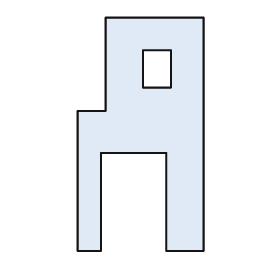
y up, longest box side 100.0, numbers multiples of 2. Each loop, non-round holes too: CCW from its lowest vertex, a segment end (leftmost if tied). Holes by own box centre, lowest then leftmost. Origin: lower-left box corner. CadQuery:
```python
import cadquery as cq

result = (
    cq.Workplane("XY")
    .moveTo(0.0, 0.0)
    .lineTo(10.0, 0.0)
    .lineTo(10.0, 42.0)
    .lineTo(38.0, 42.0)
    .lineTo(38.0, 0.0)
    .lineTo(54.0, 0.0)
    .lineTo(54.0, 100.0)
    .lineTo(12.0, 100.0)
    .lineTo(12.0, 60.0)
    .lineTo(0.0, 60.0)
    .close()
    .moveTo(28.0, 70.0)
    .lineTo(40.0, 70.0)
    .lineTo(40.0, 86.0)
    .lineTo(28.0, 86.0)
    .close()
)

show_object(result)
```